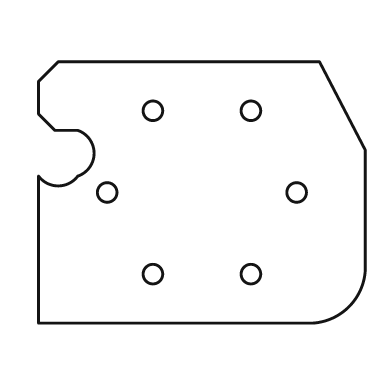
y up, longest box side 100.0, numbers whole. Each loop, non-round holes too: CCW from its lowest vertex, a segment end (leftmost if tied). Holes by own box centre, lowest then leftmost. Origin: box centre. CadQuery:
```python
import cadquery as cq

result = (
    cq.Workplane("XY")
    .moveTo(-50.0, -40.0)
    .lineTo(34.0, -40.0)
    .threePointArc((45.0, -35.0), (50.0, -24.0))
    .lineTo(50.0, 13.0)
    .lineTo(36.0, 40.0)
    .lineTo(-44.0, 40.0)
    .lineTo(-50.0, 34.0)
    .lineTo(-50.0, 24.0)
    .lineTo(-45.0, 19.0)
    .lineTo(-38.0, 19.0)
    .threePointArc((-33.0, 12.0), (-38.0, 5.0))
    .threePointArc((-44.0, 2.0), (-50.0, 5.0))
    .close()
    .moveTo(-15.0, -25.0)
    .circle(3.0)
    .moveTo(15.0, -25.0)
    .circle(3.0)
    .moveTo(-29.0, 0.0)
    .circle(3.0)
    .moveTo(29.0, 0.0)
    .circle(3.0)
    .moveTo(-15.0, 25.0)
    .circle(3.0)
    .moveTo(15.0, 25.0)
    .circle(3.0)
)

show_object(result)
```